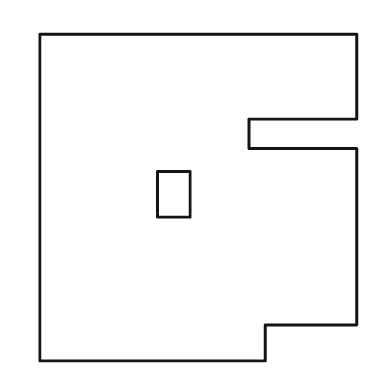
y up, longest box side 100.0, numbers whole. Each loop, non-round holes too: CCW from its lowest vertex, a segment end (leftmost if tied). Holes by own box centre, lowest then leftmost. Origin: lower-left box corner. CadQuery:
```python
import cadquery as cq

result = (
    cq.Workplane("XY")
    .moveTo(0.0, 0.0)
    .lineTo(69.0, 0.0)
    .lineTo(69.0, 11.0)
    .lineTo(97.0, 11.0)
    .lineTo(97.0, 65.0)
    .lineTo(64.0, 65.0)
    .lineTo(64.0, 74.0)
    .lineTo(97.0, 74.0)
    .lineTo(97.0, 100.0)
    .lineTo(0.0, 100.0)
    .close()
    .moveTo(36.0, 44.0)
    .lineTo(46.0, 44.0)
    .lineTo(46.0, 58.0)
    .lineTo(36.0, 58.0)
    .close()
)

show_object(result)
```